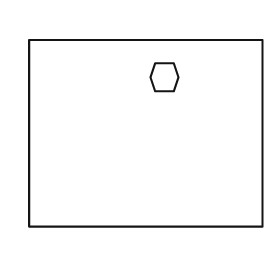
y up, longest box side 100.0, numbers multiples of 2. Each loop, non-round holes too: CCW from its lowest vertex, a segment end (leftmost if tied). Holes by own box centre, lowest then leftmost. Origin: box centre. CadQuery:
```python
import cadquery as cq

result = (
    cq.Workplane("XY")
    .moveTo(-50.0, -40.0)
    .lineTo(50.0, -40.0)
    .lineTo(50.0, 40.0)
    .lineTo(-50.0, 40.0)
    .close()
    .moveTo(4.0, 18.0)
    .lineTo(12.0, 18.0)
    .lineTo(14.0, 24.0)
    .lineTo(12.0, 30.0)
    .lineTo(4.0, 30.0)
    .lineTo(2.0, 24.0)
    .close()
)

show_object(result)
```